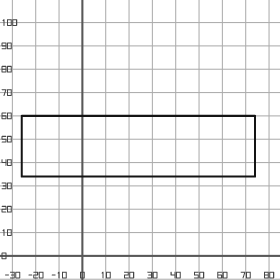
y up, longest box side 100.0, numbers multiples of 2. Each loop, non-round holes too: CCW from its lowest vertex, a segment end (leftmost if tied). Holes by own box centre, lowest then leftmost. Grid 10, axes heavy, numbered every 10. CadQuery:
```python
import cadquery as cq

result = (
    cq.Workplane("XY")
    .moveTo(-26.0, 34.0)
    .lineTo(74.0, 34.0)
    .lineTo(74.0, 60.0)
    .lineTo(-26.0, 60.0)
    .close()
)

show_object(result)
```